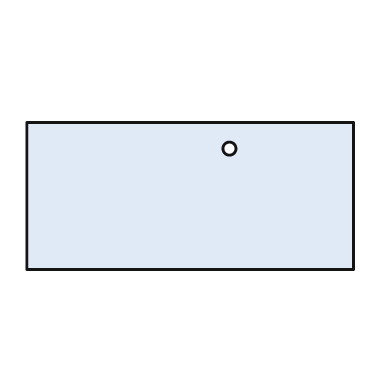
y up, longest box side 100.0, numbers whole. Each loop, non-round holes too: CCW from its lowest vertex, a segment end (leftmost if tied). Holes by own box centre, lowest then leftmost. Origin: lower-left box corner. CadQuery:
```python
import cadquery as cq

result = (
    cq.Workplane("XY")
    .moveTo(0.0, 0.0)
    .lineTo(100.0, 0.0)
    .lineTo(100.0, 45.0)
    .lineTo(0.0, 45.0)
    .close()
    .moveTo(62.0, 37.0)
    .circle(2.0)
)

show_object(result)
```